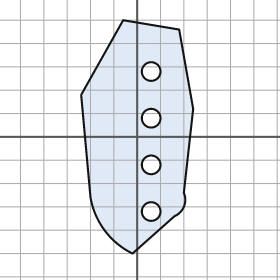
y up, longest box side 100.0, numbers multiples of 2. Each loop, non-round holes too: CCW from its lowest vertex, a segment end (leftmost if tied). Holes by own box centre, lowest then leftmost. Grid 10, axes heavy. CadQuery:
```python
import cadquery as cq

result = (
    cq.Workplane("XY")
    .moveTo(-2.0, -50.0)
    .lineTo(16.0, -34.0)
    .threePointArc((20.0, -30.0), (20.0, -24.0))
    .lineTo(24.0, 12.0)
    .lineTo(18.0, 46.0)
    .lineTo(-6.0, 50.0)
    .lineTo(-24.0, 18.0)
    .lineTo(-20.0, -26.0)
    .threePointArc((-14.0, -40.0), (-2.0, -50.0))
    .close()
    .moveTo(6.0, -32.0)
    .circle(4.0)
    .moveTo(6.0, -12.0)
    .circle(4.0)
    .moveTo(6.0, 8.0)
    .circle(4.0)
    .moveTo(6.0, 28.0)
    .circle(4.0)
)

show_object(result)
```